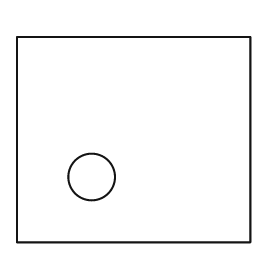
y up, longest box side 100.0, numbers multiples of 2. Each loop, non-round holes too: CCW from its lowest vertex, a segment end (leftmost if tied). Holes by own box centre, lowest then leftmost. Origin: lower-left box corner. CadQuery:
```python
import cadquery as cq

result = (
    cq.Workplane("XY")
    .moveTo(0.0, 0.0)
    .lineTo(100.0, 0.0)
    .lineTo(100.0, 88.0)
    .lineTo(0.0, 88.0)
    .close()
    .moveTo(32.0, 28.0)
    .circle(10.0)
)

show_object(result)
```